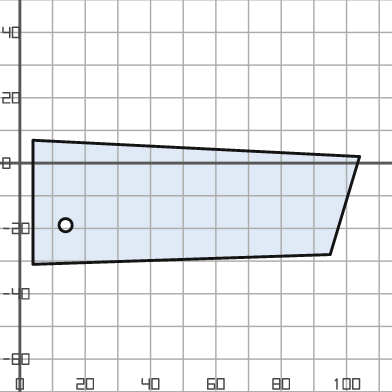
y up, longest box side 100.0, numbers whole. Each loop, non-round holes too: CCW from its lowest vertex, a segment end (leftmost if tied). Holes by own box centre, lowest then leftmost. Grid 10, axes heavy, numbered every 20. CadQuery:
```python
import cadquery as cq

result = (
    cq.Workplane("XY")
    .moveTo(4.0, -31.0)
    .lineTo(95.0, -28.0)
    .lineTo(104.0, 2.0)
    .lineTo(4.0, 7.0)
    .close()
    .moveTo(14.0, -19.0)
    .circle(2.0)
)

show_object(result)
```